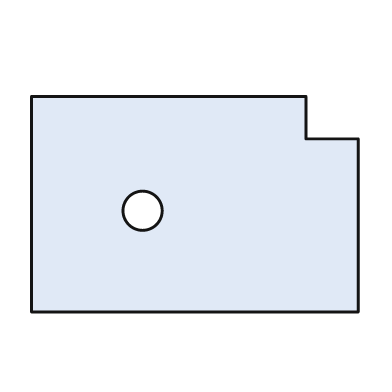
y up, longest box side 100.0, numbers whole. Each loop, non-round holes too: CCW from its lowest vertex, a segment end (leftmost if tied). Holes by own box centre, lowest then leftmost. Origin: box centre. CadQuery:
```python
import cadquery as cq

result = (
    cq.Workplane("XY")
    .moveTo(-50.0, -33.0)
    .lineTo(50.0, -33.0)
    .lineTo(50.0, 20.0)
    .lineTo(34.0, 20.0)
    .lineTo(34.0, 33.0)
    .lineTo(-50.0, 33.0)
    .close()
    .moveTo(-16.0, -2.0)
    .circle(6.0)
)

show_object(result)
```